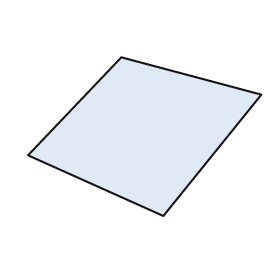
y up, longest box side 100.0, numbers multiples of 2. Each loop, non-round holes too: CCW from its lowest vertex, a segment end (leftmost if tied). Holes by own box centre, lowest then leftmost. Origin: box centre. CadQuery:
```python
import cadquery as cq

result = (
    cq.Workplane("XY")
    .moveTo(8.0, -34.0)
    .lineTo(50.0, 18.0)
    .lineTo(-10.0, 34.0)
    .lineTo(-50.0, -8.0)
    .close()
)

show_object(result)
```